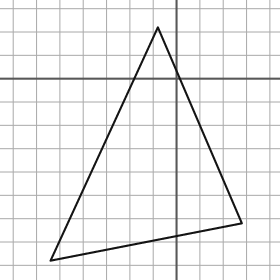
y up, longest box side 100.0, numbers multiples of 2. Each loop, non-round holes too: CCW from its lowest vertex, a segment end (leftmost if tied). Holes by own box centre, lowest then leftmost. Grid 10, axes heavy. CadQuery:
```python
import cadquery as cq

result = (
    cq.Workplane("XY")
    .moveTo(-54.0, -78.0)
    .lineTo(28.0, -62.0)
    .lineTo(-8.0, 22.0)
    .close()
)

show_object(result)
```